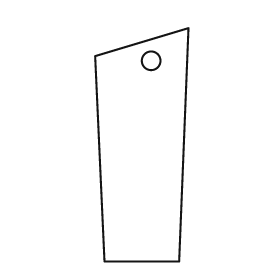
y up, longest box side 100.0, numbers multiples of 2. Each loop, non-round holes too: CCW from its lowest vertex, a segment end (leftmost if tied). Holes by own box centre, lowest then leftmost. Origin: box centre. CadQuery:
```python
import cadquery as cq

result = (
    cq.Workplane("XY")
    .moveTo(-16.0, -50.0)
    .lineTo(16.0, -50.0)
    .lineTo(20.0, 50.0)
    .lineTo(-20.0, 38.0)
    .close()
    .moveTo(4.0, 36.0)
    .circle(4.0)
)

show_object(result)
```